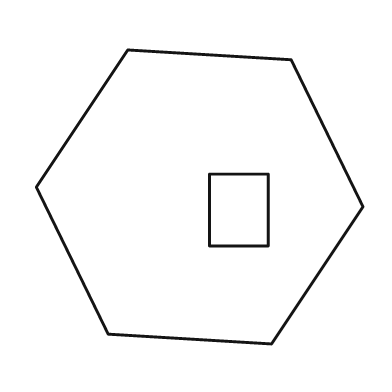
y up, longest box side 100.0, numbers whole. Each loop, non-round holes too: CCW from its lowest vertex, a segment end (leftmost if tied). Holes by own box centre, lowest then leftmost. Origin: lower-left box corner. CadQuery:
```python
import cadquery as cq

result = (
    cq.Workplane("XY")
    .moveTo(72.0, 0.0)
    .lineTo(100.0, 42.0)
    .lineTo(78.0, 87.0)
    .lineTo(28.0, 90.0)
    .lineTo(0.0, 48.0)
    .lineTo(22.0, 3.0)
    .close()
    .moveTo(53.0, 30.0)
    .lineTo(71.0, 30.0)
    .lineTo(71.0, 52.0)
    .lineTo(53.0, 52.0)
    .close()
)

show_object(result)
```